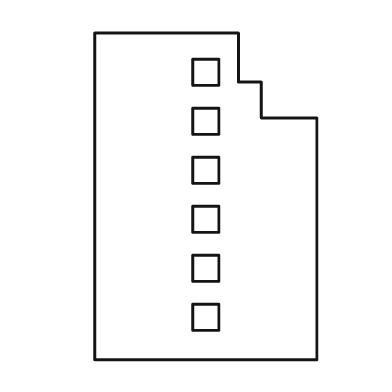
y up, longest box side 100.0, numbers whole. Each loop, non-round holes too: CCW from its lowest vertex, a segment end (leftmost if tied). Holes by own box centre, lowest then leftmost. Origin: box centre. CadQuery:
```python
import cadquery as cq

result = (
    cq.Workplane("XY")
    .moveTo(-34.0, -50.0)
    .lineTo(34.0, -50.0)
    .lineTo(34.0, 24.0)
    .lineTo(17.0, 24.0)
    .lineTo(17.0, 35.0)
    .lineTo(10.0, 35.0)
    .lineTo(10.0, 50.0)
    .lineTo(-34.0, 50.0)
    .close()
    .moveTo(-4.0, -41.0)
    .lineTo(4.0, -41.0)
    .lineTo(4.0, -33.0)
    .lineTo(-4.0, -33.0)
    .close()
    .moveTo(-4.0, -26.0)
    .lineTo(4.0, -26.0)
    .lineTo(4.0, -18.0)
    .lineTo(-4.0, -18.0)
    .close()
    .moveTo(-4.0, -11.0)
    .lineTo(4.0, -11.0)
    .lineTo(4.0, -3.0)
    .lineTo(-4.0, -3.0)
    .close()
    .moveTo(-4.0, 4.0)
    .lineTo(4.0, 4.0)
    .lineTo(4.0, 12.0)
    .lineTo(-4.0, 12.0)
    .close()
    .moveTo(-4.0, 19.0)
    .lineTo(4.0, 19.0)
    .lineTo(4.0, 27.0)
    .lineTo(-4.0, 27.0)
    .close()
    .moveTo(-4.0, 34.0)
    .lineTo(4.0, 34.0)
    .lineTo(4.0, 42.0)
    .lineTo(-4.0, 42.0)
    .close()
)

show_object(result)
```